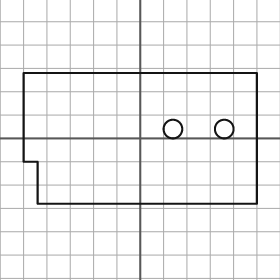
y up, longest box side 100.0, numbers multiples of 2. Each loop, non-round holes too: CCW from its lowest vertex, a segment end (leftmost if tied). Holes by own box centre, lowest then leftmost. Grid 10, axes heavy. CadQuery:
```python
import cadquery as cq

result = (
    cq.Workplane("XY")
    .moveTo(-44.0, -28.0)
    .lineTo(50.0, -28.0)
    .lineTo(50.0, 28.0)
    .lineTo(-50.0, 28.0)
    .lineTo(-50.0, -10.0)
    .lineTo(-44.0, -10.0)
    .close()
    .moveTo(14.0, 4.0)
    .circle(4.0)
    .moveTo(36.0, 4.0)
    .circle(4.0)
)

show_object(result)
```